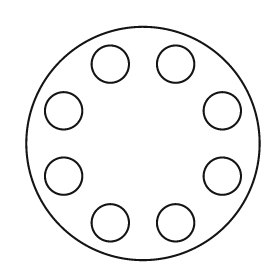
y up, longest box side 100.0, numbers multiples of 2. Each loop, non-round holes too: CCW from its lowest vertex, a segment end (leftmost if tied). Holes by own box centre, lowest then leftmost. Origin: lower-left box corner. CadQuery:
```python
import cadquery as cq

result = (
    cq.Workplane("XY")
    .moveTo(50.0, 50.0)
    .circle(50.0)
    .moveTo(36.0, 16.0)
    .circle(8.0)
    .moveTo(64.0, 16.0)
    .circle(8.0)
    .moveTo(16.0, 36.0)
    .circle(8.0)
    .moveTo(84.0, 36.0)
    .circle(8.0)
    .moveTo(16.0, 64.0)
    .circle(8.0)
    .moveTo(84.0, 64.0)
    .circle(8.0)
    .moveTo(36.0, 84.0)
    .circle(8.0)
    .moveTo(64.0, 84.0)
    .circle(8.0)
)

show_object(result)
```